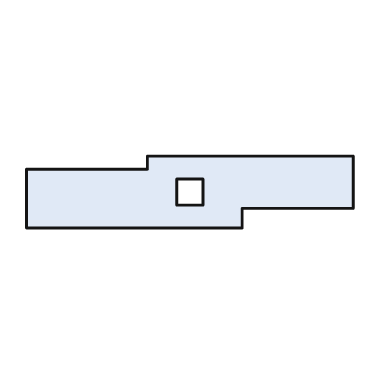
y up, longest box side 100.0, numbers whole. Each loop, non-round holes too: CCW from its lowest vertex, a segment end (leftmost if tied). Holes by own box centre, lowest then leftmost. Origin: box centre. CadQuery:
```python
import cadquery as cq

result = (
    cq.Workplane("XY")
    .moveTo(-50.0, -11.0)
    .lineTo(16.0, -11.0)
    .lineTo(16.0, -5.0)
    .lineTo(50.0, -5.0)
    .lineTo(50.0, 11.0)
    .lineTo(-13.0, 11.0)
    .lineTo(-13.0, 7.0)
    .lineTo(-50.0, 7.0)
    .close()
    .moveTo(-4.0, -4.0)
    .lineTo(4.0, -4.0)
    .lineTo(4.0, 4.0)
    .lineTo(-4.0, 4.0)
    .close()
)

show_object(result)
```